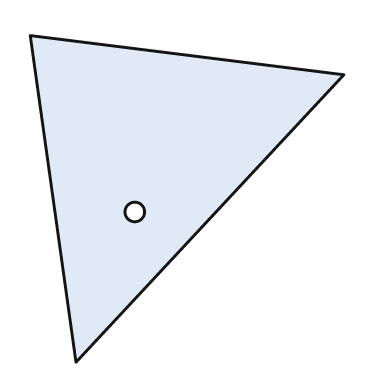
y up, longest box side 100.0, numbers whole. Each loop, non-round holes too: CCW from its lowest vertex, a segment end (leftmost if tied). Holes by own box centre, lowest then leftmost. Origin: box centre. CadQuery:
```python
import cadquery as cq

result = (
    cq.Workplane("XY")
    .moveTo(-34.0, -50.0)
    .lineTo(48.0, 38.0)
    .lineTo(-48.0, 50.0)
    .close()
    .moveTo(-16.0, -4.0)
    .circle(3.0)
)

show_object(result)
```